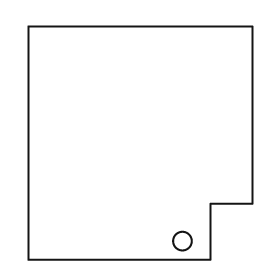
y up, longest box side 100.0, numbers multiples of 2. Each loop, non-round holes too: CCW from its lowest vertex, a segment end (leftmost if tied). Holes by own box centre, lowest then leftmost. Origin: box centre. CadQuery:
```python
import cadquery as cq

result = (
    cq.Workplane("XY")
    .moveTo(-48.0, -50.0)
    .lineTo(30.0, -50.0)
    .lineTo(30.0, -26.0)
    .lineTo(48.0, -26.0)
    .lineTo(48.0, 50.0)
    .lineTo(-48.0, 50.0)
    .close()
    .moveTo(18.0, -42.0)
    .circle(4.0)
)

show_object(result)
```